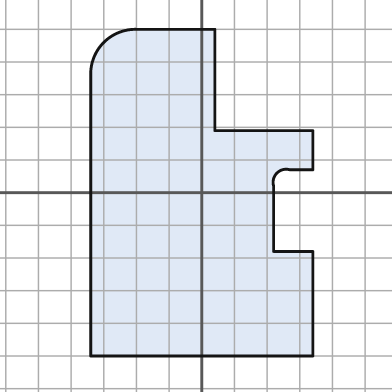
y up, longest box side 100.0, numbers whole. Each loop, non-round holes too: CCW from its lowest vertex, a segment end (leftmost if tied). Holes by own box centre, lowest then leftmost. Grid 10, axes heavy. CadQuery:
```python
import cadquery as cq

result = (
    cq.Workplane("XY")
    .moveTo(-34.0, -50.0)
    .lineTo(34.0, -50.0)
    .lineTo(34.0, -18.0)
    .lineTo(22.0, -18.0)
    .lineTo(22.0, 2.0)
    .threePointArc((23.0, 6.0), (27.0, 7.0))
    .lineTo(34.0, 7.0)
    .lineTo(34.0, 19.0)
    .lineTo(4.0, 19.0)
    .lineTo(4.0, 50.0)
    .lineTo(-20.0, 50.0)
    .threePointArc((-30.0, 46.0), (-34.0, 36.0))
    .close()
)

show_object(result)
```